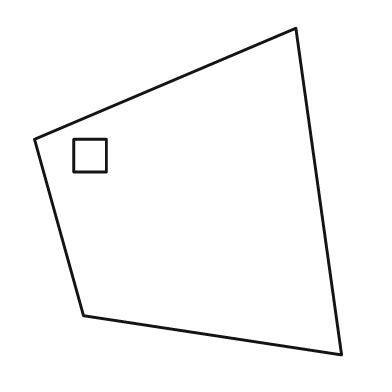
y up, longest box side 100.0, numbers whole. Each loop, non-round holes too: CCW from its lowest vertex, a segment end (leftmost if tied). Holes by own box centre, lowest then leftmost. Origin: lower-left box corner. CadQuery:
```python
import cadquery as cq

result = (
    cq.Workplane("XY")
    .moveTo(94.0, 0.0)
    .lineTo(80.0, 100.0)
    .lineTo(0.0, 66.0)
    .lineTo(15.0, 12.0)
    .close()
    .moveTo(12.0, 56.0)
    .lineTo(22.0, 56.0)
    .lineTo(22.0, 66.0)
    .lineTo(12.0, 66.0)
    .close()
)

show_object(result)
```